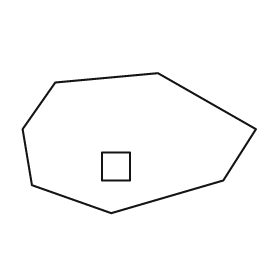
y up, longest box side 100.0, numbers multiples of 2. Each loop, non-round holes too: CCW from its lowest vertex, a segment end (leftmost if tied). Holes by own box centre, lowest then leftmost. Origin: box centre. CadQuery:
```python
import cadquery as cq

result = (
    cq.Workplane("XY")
    .moveTo(-12.0, -30.0)
    .lineTo(36.0, -16.0)
    .lineTo(50.0, 6.0)
    .lineTo(8.0, 30.0)
    .lineTo(-36.0, 26.0)
    .lineTo(-50.0, 6.0)
    .lineTo(-46.0, -18.0)
    .close()
    .moveTo(-16.0, -16.0)
    .lineTo(-4.0, -16.0)
    .lineTo(-4.0, -4.0)
    .lineTo(-16.0, -4.0)
    .close()
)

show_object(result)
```